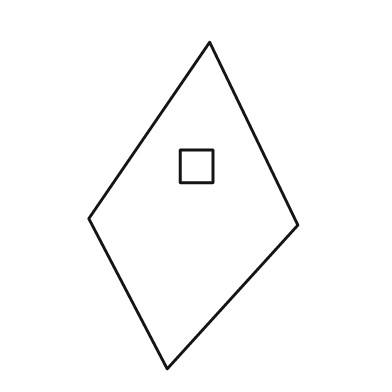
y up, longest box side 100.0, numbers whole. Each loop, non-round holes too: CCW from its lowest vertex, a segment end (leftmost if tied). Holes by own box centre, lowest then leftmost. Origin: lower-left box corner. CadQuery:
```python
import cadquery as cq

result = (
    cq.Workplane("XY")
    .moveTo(24.0, 0.0)
    .lineTo(64.0, 44.0)
    .lineTo(37.0, 100.0)
    .lineTo(0.0, 46.0)
    .close()
    .moveTo(28.0, 57.0)
    .lineTo(38.0, 57.0)
    .lineTo(38.0, 67.0)
    .lineTo(28.0, 67.0)
    .close()
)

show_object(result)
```